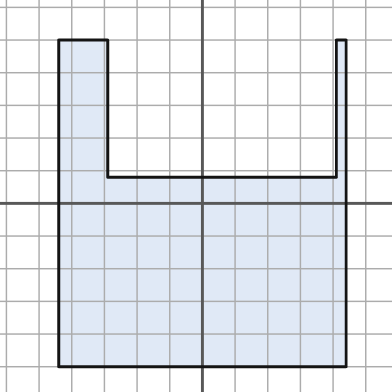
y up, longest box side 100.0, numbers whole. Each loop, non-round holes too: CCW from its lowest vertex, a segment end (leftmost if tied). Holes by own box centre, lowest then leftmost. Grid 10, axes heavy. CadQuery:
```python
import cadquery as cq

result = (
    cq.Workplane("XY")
    .moveTo(-44.0, -50.0)
    .lineTo(44.0, -50.0)
    .lineTo(44.0, 50.0)
    .lineTo(41.0, 50.0)
    .lineTo(41.0, 8.0)
    .lineTo(-29.0, 8.0)
    .lineTo(-29.0, 50.0)
    .lineTo(-44.0, 50.0)
    .close()
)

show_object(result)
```